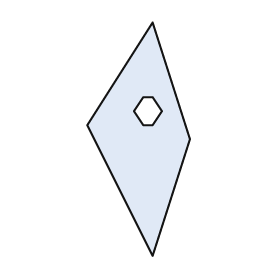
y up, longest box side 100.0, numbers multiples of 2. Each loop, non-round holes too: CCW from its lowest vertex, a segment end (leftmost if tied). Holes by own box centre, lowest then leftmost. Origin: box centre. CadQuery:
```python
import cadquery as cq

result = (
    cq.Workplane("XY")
    .moveTo(6.0, -50.0)
    .lineTo(22.0, 0.0)
    .lineTo(6.0, 50.0)
    .lineTo(-22.0, 6.0)
    .close()
    .moveTo(2.0, 6.0)
    .lineTo(6.0, 6.0)
    .lineTo(10.0, 12.0)
    .lineTo(6.0, 18.0)
    .lineTo(2.0, 18.0)
    .lineTo(-2.0, 12.0)
    .close()
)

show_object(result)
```